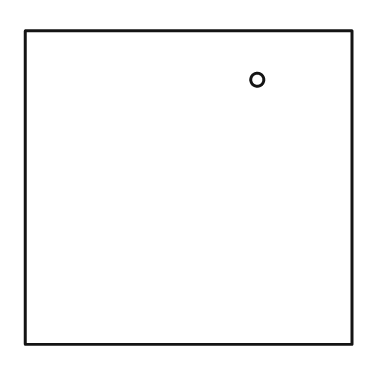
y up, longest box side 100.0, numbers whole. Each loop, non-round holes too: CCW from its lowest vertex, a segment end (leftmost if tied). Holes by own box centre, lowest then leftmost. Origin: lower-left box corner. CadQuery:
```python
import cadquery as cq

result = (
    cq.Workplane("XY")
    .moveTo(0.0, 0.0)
    .lineTo(100.0, 0.0)
    .lineTo(100.0, 96.0)
    .lineTo(0.0, 96.0)
    .close()
    .moveTo(71.0, 81.0)
    .circle(2.0)
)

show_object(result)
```